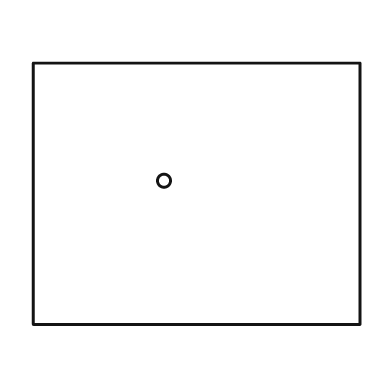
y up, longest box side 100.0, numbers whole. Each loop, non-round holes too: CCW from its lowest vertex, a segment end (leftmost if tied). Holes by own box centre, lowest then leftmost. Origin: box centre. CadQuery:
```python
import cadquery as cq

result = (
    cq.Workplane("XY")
    .moveTo(-50.0, -40.0)
    .lineTo(50.0, -40.0)
    .lineTo(50.0, 40.0)
    .lineTo(-50.0, 40.0)
    .close()
    .moveTo(-10.0, 4.0)
    .circle(2.0)
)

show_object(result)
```